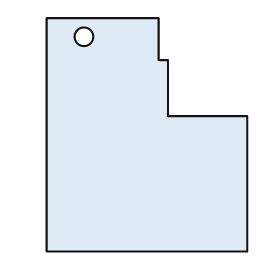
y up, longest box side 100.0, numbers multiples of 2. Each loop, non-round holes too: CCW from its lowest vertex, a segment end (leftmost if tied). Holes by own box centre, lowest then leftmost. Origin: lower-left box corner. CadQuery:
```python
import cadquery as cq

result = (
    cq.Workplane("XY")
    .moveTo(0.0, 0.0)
    .lineTo(86.0, 0.0)
    .lineTo(86.0, 58.0)
    .lineTo(52.0, 58.0)
    .lineTo(52.0, 82.0)
    .lineTo(48.0, 82.0)
    .lineTo(48.0, 100.0)
    .lineTo(0.0, 100.0)
    .close()
    .moveTo(16.0, 92.0)
    .circle(4.0)
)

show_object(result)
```